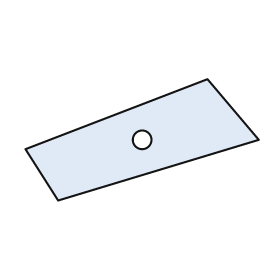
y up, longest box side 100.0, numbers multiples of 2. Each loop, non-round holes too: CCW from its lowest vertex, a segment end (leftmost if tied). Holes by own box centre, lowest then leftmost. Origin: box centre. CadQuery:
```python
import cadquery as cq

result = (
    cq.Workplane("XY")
    .moveTo(-36.0, -26.0)
    .lineTo(50.0, 0.0)
    .lineTo(28.0, 26.0)
    .lineTo(-50.0, -4.0)
    .close()
    .moveTo(0.0, 0.0)
    .circle(4.0)
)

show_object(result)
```